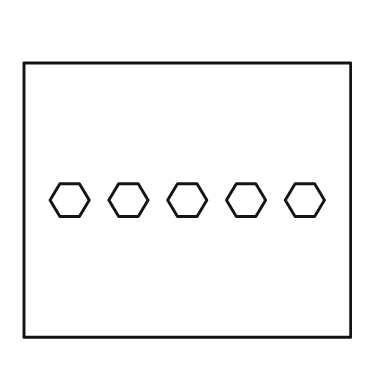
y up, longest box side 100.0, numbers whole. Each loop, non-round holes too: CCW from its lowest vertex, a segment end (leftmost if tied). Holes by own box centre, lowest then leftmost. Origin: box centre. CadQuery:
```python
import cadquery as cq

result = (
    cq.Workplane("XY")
    .moveTo(-50.0, -42.0)
    .lineTo(50.0, -42.0)
    .lineTo(50.0, 42.0)
    .lineTo(-50.0, 42.0)
    .close()
    .moveTo(-39.0, -5.0)
    .lineTo(-33.0, -5.0)
    .lineTo(-30.0, 0.0)
    .lineTo(-33.0, 5.0)
    .lineTo(-39.0, 5.0)
    .lineTo(-42.0, 0.0)
    .close()
    .moveTo(-21.0, -5.0)
    .lineTo(-15.0, -5.0)
    .lineTo(-12.0, 0.0)
    .lineTo(-15.0, 5.0)
    .lineTo(-21.0, 5.0)
    .lineTo(-24.0, 0.0)
    .close()
    .moveTo(-3.0, -5.0)
    .lineTo(3.0, -5.0)
    .lineTo(6.0, 0.0)
    .lineTo(3.0, 5.0)
    .lineTo(-3.0, 5.0)
    .lineTo(-6.0, 0.0)
    .close()
    .moveTo(15.0, -5.0)
    .lineTo(21.0, -5.0)
    .lineTo(24.0, 0.0)
    .lineTo(21.0, 5.0)
    .lineTo(15.0, 5.0)
    .lineTo(12.0, 0.0)
    .close()
    .moveTo(33.0, -5.0)
    .lineTo(39.0, -5.0)
    .lineTo(42.0, 0.0)
    .lineTo(39.0, 5.0)
    .lineTo(33.0, 5.0)
    .lineTo(30.0, 0.0)
    .close()
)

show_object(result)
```